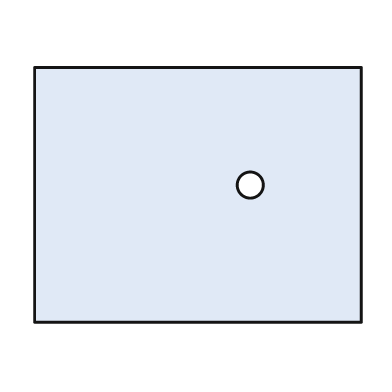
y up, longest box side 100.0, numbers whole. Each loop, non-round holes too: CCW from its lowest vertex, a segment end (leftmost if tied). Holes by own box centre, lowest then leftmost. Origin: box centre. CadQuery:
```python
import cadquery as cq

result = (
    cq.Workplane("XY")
    .moveTo(-50.0, -39.0)
    .lineTo(50.0, -39.0)
    .lineTo(50.0, 39.0)
    .lineTo(-50.0, 39.0)
    .close()
    .moveTo(16.0, 3.0)
    .circle(4.0)
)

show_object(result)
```